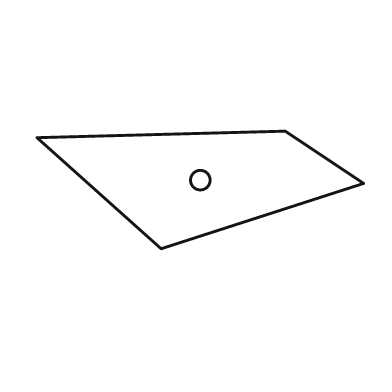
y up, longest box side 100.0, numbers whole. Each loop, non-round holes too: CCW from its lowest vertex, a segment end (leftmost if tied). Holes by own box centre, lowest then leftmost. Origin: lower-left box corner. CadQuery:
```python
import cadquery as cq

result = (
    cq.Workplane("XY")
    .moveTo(38.0, 0.0)
    .lineTo(100.0, 20.0)
    .lineTo(76.0, 36.0)
    .lineTo(0.0, 34.0)
    .close()
    .moveTo(50.0, 21.0)
    .circle(3.0)
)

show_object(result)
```